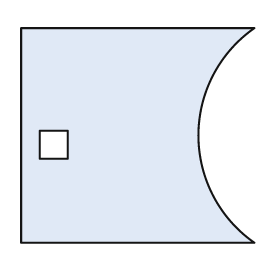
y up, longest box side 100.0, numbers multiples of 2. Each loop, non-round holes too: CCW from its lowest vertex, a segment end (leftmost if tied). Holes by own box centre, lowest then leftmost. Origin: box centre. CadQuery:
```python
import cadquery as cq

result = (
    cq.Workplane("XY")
    .moveTo(-50.0, -46.0)
    .lineTo(50.0, -46.0)
    .threePointArc((26.0, 0.0), (50.0, 46.0))
    .lineTo(-50.0, 46.0)
    .close()
    .moveTo(-42.0, -10.0)
    .lineTo(-30.0, -10.0)
    .lineTo(-30.0, 2.0)
    .lineTo(-42.0, 2.0)
    .close()
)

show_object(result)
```